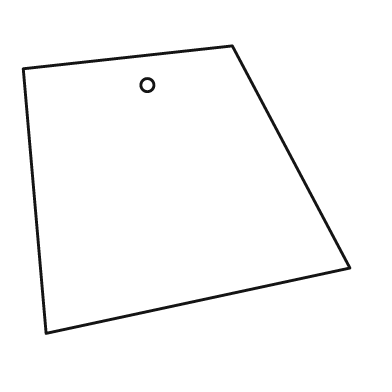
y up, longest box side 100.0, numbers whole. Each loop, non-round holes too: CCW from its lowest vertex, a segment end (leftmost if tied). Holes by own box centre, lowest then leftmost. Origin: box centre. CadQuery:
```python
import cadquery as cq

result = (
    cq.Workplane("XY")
    .moveTo(-43.0, -44.0)
    .lineTo(50.0, -24.0)
    .lineTo(14.0, 44.0)
    .lineTo(-50.0, 37.0)
    .close()
    .moveTo(-12.0, 32.0)
    .circle(2.0)
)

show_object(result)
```